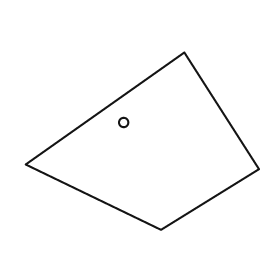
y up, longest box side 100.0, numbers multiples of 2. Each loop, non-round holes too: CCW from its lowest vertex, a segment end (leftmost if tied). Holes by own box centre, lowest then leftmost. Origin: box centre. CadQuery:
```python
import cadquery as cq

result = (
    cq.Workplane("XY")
    .moveTo(8.0, -38.0)
    .lineTo(50.0, -12.0)
    .lineTo(18.0, 38.0)
    .lineTo(-50.0, -10.0)
    .close()
    .moveTo(-8.0, 8.0)
    .circle(2.0)
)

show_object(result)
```